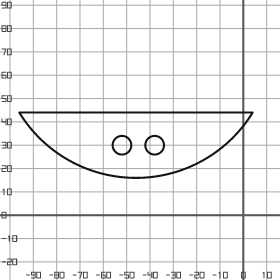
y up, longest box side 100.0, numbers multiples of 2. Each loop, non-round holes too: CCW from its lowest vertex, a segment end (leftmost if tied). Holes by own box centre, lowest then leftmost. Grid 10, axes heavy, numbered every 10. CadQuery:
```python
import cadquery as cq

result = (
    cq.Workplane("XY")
    .moveTo(-96.0, 44.0)
    .threePointArc((-46.0, 16.0), (4.0, 44.0))
    .close()
    .moveTo(-52.0, 30.0)
    .circle(4.0)
    .moveTo(-38.0, 30.0)
    .circle(4.0)
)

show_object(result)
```